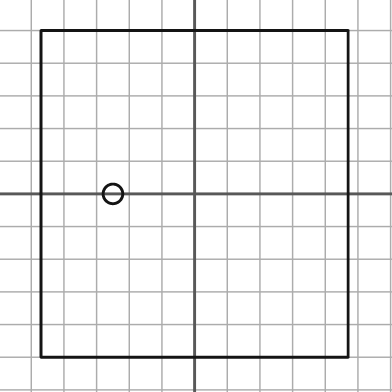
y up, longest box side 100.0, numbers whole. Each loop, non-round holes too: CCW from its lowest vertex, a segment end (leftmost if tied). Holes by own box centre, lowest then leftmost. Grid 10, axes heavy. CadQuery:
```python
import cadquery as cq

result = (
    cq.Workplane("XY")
    .moveTo(-47.0, -50.0)
    .lineTo(47.0, -50.0)
    .lineTo(47.0, 50.0)
    .lineTo(-47.0, 50.0)
    .close()
    .moveTo(-25.0, 0.0)
    .circle(3.0)
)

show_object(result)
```